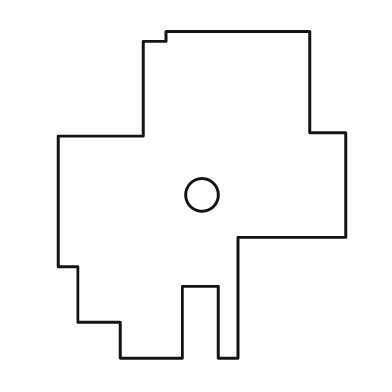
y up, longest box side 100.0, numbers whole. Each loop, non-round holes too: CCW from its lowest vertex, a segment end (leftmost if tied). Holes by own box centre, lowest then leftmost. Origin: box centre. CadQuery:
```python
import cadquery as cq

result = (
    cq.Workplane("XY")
    .moveTo(-25.0, -50.0)
    .lineTo(-6.0, -50.0)
    .lineTo(-6.0, -28.0)
    .lineTo(5.0, -28.0)
    .lineTo(5.0, -50.0)
    .lineTo(11.0, -50.0)
    .lineTo(11.0, -13.0)
    .lineTo(44.0, -13.0)
    .lineTo(44.0, 19.0)
    .lineTo(33.0, 19.0)
    .lineTo(33.0, 50.0)
    .lineTo(-11.0, 50.0)
    .lineTo(-11.0, 47.0)
    .lineTo(-18.0, 47.0)
    .lineTo(-18.0, 18.0)
    .lineTo(-44.0, 18.0)
    .lineTo(-44.0, -22.0)
    .lineTo(-38.0, -22.0)
    .lineTo(-38.0, -39.0)
    .lineTo(-25.0, -39.0)
    .close()
    .moveTo(0.0, 0.0)
    .circle(5.0)
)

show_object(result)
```